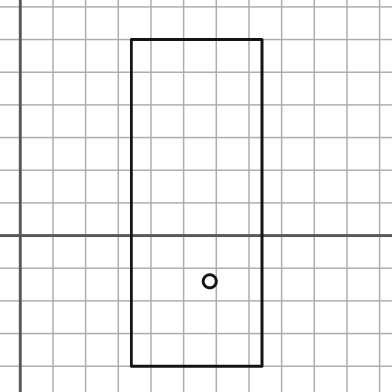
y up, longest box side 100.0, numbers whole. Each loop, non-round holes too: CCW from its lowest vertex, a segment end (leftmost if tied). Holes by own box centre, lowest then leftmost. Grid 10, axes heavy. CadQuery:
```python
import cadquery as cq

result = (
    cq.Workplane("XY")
    .moveTo(34.0, -40.0)
    .lineTo(74.0, -40.0)
    .lineTo(74.0, 60.0)
    .lineTo(34.0, 60.0)
    .close()
    .moveTo(58.0, -14.0)
    .circle(2.0)
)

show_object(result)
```